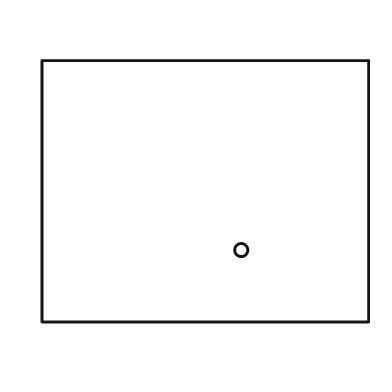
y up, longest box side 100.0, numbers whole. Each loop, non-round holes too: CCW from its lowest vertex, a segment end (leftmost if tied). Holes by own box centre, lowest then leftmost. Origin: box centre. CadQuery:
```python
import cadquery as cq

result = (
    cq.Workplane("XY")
    .moveTo(-50.0, -40.0)
    .lineTo(50.0, -40.0)
    .lineTo(50.0, 40.0)
    .lineTo(-50.0, 40.0)
    .close()
    .moveTo(11.0, -18.0)
    .circle(2.0)
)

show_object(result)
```